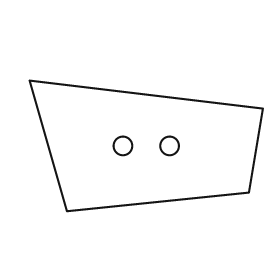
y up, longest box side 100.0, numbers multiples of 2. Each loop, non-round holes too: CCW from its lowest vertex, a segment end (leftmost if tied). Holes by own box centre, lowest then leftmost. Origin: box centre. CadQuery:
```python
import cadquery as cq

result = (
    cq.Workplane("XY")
    .moveTo(-34.0, -28.0)
    .lineTo(44.0, -20.0)
    .lineTo(50.0, 16.0)
    .lineTo(-50.0, 28.0)
    .close()
    .moveTo(-10.0, 0.0)
    .circle(4.0)
    .moveTo(10.0, 0.0)
    .circle(4.0)
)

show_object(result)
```